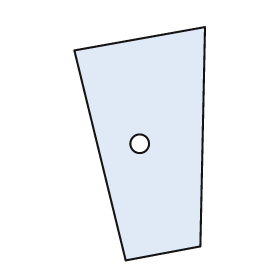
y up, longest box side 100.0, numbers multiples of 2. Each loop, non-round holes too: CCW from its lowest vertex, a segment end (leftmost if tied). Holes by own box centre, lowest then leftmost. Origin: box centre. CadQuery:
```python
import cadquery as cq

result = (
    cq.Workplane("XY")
    .moveTo(-6.0, -50.0)
    .lineTo(26.0, -44.0)
    .lineTo(28.0, 50.0)
    .lineTo(-28.0, 40.0)
    .close()
    .moveTo(0.0, 0.0)
    .circle(4.0)
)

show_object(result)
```